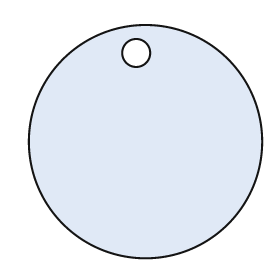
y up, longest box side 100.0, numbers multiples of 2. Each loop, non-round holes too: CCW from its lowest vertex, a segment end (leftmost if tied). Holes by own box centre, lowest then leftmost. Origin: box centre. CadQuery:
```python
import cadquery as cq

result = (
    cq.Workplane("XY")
    .moveTo(0.0, 0.0)
    .circle(50.0)
    .moveTo(-4.0, 38.0)
    .circle(6.0)
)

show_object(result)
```